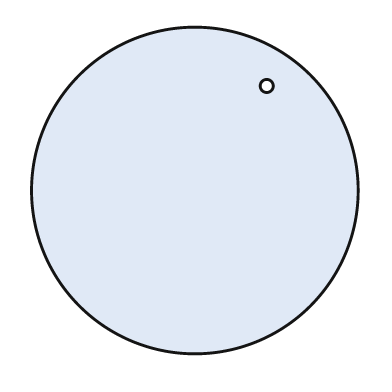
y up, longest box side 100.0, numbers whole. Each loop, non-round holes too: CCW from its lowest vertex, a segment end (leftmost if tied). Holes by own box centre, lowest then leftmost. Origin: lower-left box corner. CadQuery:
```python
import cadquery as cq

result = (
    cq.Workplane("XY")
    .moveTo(50.0, 50.0)
    .circle(50.0)
    .moveTo(72.0, 82.0)
    .circle(2.0)
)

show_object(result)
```